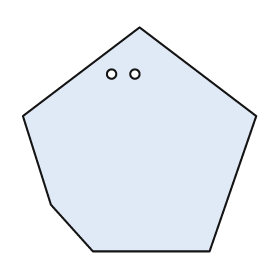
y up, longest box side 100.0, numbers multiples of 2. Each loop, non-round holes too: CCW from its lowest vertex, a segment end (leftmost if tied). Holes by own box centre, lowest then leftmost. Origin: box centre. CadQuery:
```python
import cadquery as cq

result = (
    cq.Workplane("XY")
    .moveTo(-20.0, -48.0)
    .lineTo(30.0, -48.0)
    .lineTo(50.0, 10.0)
    .lineTo(0.0, 48.0)
    .lineTo(-50.0, 10.0)
    .lineTo(-38.0, -28.0)
    .close()
    .moveTo(-12.0, 28.0)
    .circle(2.0)
    .moveTo(-2.0, 28.0)
    .circle(2.0)
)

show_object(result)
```